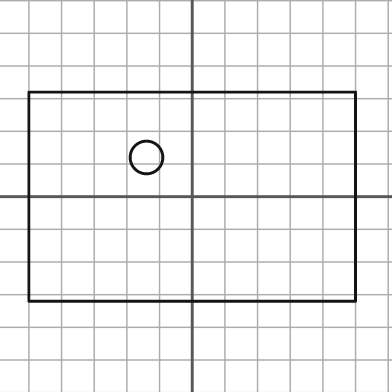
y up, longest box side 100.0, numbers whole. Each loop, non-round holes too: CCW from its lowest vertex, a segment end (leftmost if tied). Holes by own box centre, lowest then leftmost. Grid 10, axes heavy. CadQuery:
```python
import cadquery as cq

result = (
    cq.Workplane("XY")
    .moveTo(-50.0, -32.0)
    .lineTo(50.0, -32.0)
    .lineTo(50.0, 32.0)
    .lineTo(-50.0, 32.0)
    .close()
    .moveTo(-14.0, 12.0)
    .circle(5.0)
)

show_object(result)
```